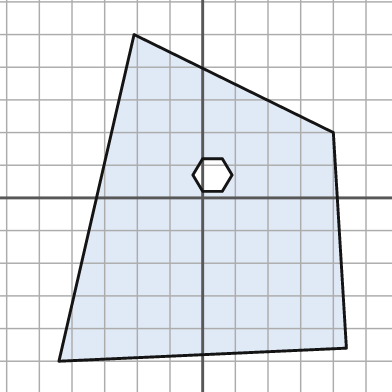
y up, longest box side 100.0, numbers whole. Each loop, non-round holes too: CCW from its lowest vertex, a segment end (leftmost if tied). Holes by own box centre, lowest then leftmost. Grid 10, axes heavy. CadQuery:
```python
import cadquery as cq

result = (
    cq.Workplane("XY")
    .moveTo(-44.0, -50.0)
    .lineTo(44.0, -46.0)
    .lineTo(40.0, 20.0)
    .lineTo(-21.0, 50.0)
    .close()
    .moveTo(0.0, 2.0)
    .lineTo(6.0, 2.0)
    .lineTo(9.0, 7.0)
    .lineTo(6.0, 12.0)
    .lineTo(0.0, 12.0)
    .lineTo(-3.0, 7.0)
    .close()
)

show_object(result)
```